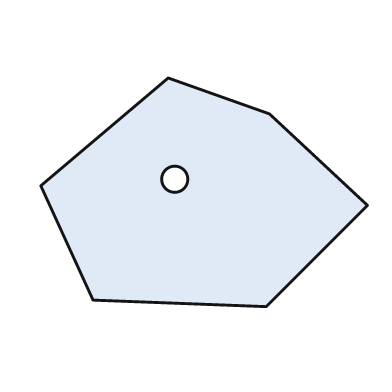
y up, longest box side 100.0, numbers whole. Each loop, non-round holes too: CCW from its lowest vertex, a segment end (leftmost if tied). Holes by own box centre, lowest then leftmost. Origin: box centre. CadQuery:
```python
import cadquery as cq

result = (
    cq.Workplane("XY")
    .moveTo(19.0, -35.0)
    .lineTo(50.0, -4.0)
    .lineTo(20.0, 24.0)
    .lineTo(-11.0, 35.0)
    .lineTo(-50.0, 2.0)
    .lineTo(-34.0, -33.0)
    .close()
    .moveTo(-9.0, 4.0)
    .circle(4.0)
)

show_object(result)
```